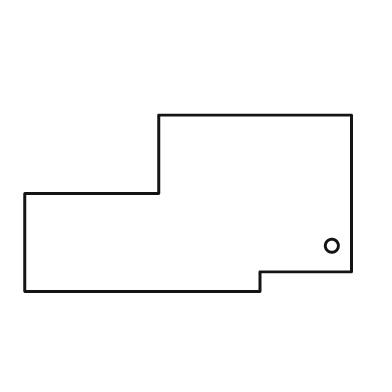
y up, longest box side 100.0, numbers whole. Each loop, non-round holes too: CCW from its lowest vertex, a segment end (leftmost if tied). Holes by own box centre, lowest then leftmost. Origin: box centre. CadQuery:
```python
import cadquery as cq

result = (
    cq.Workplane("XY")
    .moveTo(-50.0, -27.0)
    .lineTo(22.0, -27.0)
    .lineTo(22.0, -21.0)
    .lineTo(50.0, -21.0)
    .lineTo(50.0, 27.0)
    .lineTo(-9.0, 27.0)
    .lineTo(-9.0, 3.0)
    .lineTo(-50.0, 3.0)
    .close()
    .moveTo(44.0, -13.0)
    .circle(2.0)
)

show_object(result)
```